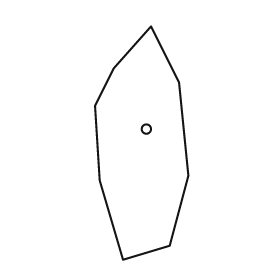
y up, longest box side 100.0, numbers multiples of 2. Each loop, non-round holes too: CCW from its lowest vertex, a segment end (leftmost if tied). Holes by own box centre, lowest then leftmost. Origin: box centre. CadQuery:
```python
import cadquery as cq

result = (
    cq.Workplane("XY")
    .moveTo(-8.0, -50.0)
    .lineTo(12.0, -44.0)
    .lineTo(20.0, -14.0)
    .lineTo(16.0, 26.0)
    .lineTo(4.0, 50.0)
    .lineTo(-12.0, 32.0)
    .lineTo(-20.0, 16.0)
    .lineTo(-18.0, -16.0)
    .close()
    .moveTo(2.0, 6.0)
    .circle(2.0)
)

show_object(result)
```